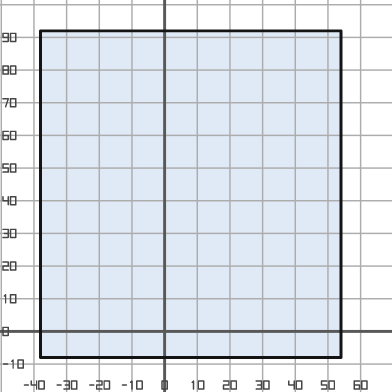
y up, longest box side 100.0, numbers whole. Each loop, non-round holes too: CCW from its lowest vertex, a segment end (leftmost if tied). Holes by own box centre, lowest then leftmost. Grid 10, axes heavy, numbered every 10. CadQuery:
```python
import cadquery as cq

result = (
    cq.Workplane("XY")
    .moveTo(-38.0, -8.0)
    .lineTo(54.0, -8.0)
    .lineTo(54.0, 92.0)
    .lineTo(-38.0, 92.0)
    .close()
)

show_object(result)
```